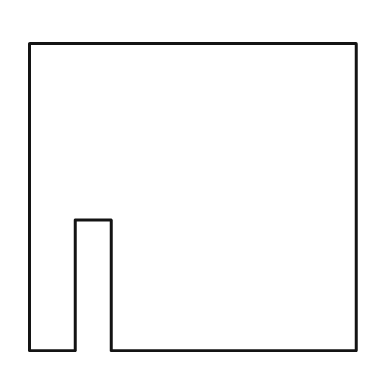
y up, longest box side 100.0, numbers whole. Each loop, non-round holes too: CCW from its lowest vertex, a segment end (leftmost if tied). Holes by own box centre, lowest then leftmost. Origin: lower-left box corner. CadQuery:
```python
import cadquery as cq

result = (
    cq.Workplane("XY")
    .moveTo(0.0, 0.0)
    .lineTo(14.0, 0.0)
    .lineTo(14.0, 40.0)
    .lineTo(25.0, 40.0)
    .lineTo(25.0, 0.0)
    .lineTo(100.0, 0.0)
    .lineTo(100.0, 94.0)
    .lineTo(0.0, 94.0)
    .close()
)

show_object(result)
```